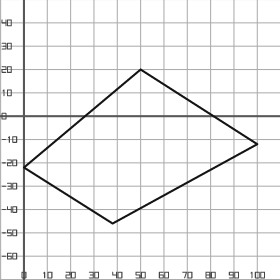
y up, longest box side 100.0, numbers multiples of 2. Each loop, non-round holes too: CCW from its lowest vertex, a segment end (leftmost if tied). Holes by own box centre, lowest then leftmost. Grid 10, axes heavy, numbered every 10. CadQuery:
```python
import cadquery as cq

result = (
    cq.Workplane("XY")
    .moveTo(38.0, -46.0)
    .lineTo(100.0, -12.0)
    .lineTo(50.0, 20.0)
    .lineTo(0.0, -22.0)
    .close()
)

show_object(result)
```